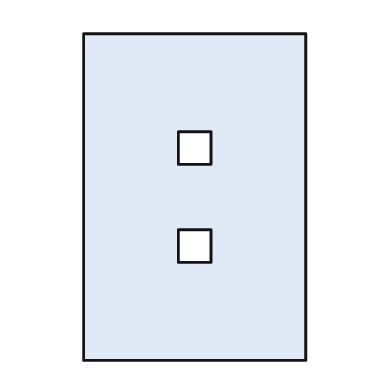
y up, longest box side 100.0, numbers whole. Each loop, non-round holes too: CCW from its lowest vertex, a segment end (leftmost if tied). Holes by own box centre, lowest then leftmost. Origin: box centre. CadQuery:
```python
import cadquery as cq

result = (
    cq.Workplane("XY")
    .moveTo(-34.0, -50.0)
    .lineTo(34.0, -50.0)
    .lineTo(34.0, 50.0)
    .lineTo(-34.0, 50.0)
    .close()
    .moveTo(-5.0, -20.0)
    .lineTo(5.0, -20.0)
    .lineTo(5.0, -10.0)
    .lineTo(-5.0, -10.0)
    .close()
    .moveTo(-5.0, 10.0)
    .lineTo(5.0, 10.0)
    .lineTo(5.0, 20.0)
    .lineTo(-5.0, 20.0)
    .close()
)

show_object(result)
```